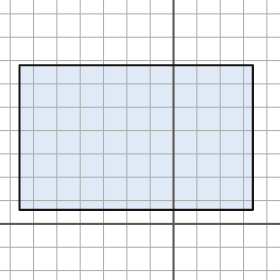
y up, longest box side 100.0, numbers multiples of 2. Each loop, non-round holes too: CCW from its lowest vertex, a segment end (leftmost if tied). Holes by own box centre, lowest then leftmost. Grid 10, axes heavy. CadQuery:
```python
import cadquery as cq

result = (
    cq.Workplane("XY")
    .moveTo(-66.0, 6.0)
    .lineTo(34.0, 6.0)
    .lineTo(34.0, 68.0)
    .lineTo(-66.0, 68.0)
    .close()
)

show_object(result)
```